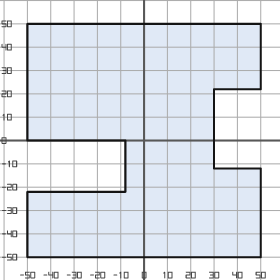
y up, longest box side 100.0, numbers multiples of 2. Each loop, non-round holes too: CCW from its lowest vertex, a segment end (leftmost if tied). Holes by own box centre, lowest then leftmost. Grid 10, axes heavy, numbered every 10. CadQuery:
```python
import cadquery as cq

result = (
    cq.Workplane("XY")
    .moveTo(-50.0, -50.0)
    .lineTo(50.0, -50.0)
    .lineTo(50.0, -12.0)
    .lineTo(30.0, -12.0)
    .lineTo(30.0, 22.0)
    .lineTo(50.0, 22.0)
    .lineTo(50.0, 50.0)
    .lineTo(-50.0, 50.0)
    .lineTo(-50.0, 0.0)
    .lineTo(-8.0, 0.0)
    .lineTo(-8.0, -22.0)
    .lineTo(-50.0, -22.0)
    .close()
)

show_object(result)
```